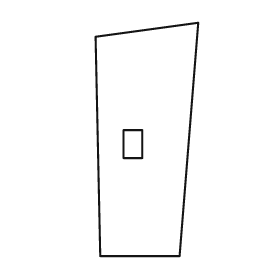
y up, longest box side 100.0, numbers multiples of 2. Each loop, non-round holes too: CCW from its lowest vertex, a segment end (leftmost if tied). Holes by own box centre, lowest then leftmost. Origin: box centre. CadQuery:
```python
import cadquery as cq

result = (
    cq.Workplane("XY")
    .moveTo(-20.0, -50.0)
    .lineTo(14.0, -50.0)
    .lineTo(22.0, 50.0)
    .lineTo(-22.0, 44.0)
    .close()
    .moveTo(-10.0, -8.0)
    .lineTo(-2.0, -8.0)
    .lineTo(-2.0, 4.0)
    .lineTo(-10.0, 4.0)
    .close()
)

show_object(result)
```